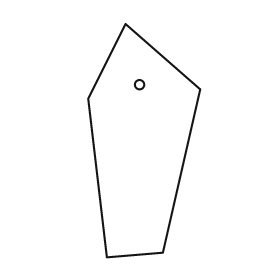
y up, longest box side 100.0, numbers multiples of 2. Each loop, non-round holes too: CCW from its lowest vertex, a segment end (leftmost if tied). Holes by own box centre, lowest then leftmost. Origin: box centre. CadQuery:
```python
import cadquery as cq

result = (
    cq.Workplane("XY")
    .moveTo(-16.0, -50.0)
    .lineTo(8.0, -48.0)
    .lineTo(24.0, 22.0)
    .lineTo(-8.0, 50.0)
    .lineTo(-24.0, 18.0)
    .close()
    .moveTo(-2.0, 24.0)
    .circle(2.0)
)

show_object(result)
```